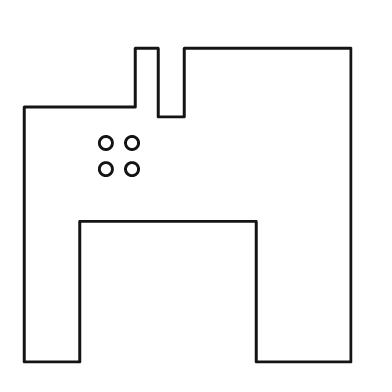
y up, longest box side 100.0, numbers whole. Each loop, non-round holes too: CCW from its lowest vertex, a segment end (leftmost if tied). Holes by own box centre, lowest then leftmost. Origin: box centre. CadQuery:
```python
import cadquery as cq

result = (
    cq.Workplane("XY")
    .moveTo(-50.0, -48.0)
    .lineTo(-33.0, -48.0)
    .lineTo(-33.0, -5.0)
    .lineTo(21.0, -5.0)
    .lineTo(21.0, -48.0)
    .lineTo(50.0, -48.0)
    .lineTo(50.0, 48.0)
    .lineTo(-1.0, 48.0)
    .lineTo(-1.0, 27.0)
    .lineTo(-9.0, 27.0)
    .lineTo(-9.0, 48.0)
    .lineTo(-16.0, 48.0)
    .lineTo(-16.0, 30.0)
    .lineTo(-50.0, 30.0)
    .close()
    .moveTo(-25.0, 11.0)
    .circle(2.0)
    .moveTo(-17.0, 11.0)
    .circle(2.0)
    .moveTo(-25.0, 19.0)
    .circle(2.0)
    .moveTo(-17.0, 19.0)
    .circle(2.0)
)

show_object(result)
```